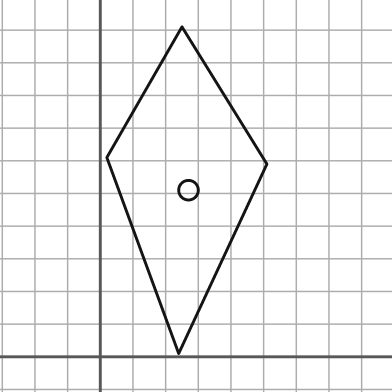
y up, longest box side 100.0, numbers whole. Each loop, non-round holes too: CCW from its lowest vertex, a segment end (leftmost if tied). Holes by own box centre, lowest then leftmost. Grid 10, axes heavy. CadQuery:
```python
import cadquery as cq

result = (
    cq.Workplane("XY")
    .moveTo(24.0, 1.0)
    .lineTo(51.0, 59.0)
    .lineTo(25.0, 101.0)
    .lineTo(2.0, 61.0)
    .close()
    .moveTo(27.0, 51.0)
    .circle(3.0)
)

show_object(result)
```